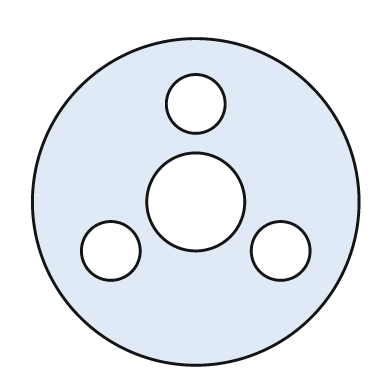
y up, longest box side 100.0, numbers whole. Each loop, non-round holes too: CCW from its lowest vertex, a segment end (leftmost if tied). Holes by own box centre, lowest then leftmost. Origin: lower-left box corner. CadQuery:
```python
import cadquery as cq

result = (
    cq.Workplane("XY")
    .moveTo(50.0, 50.0)
    .circle(50.0)
    .moveTo(24.0, 35.0)
    .circle(9.0)
    .moveTo(76.0, 35.0)
    .circle(9.0)
    .moveTo(50.0, 50.0)
    .circle(15.0)
    .moveTo(50.0, 80.0)
    .circle(9.0)
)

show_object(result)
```